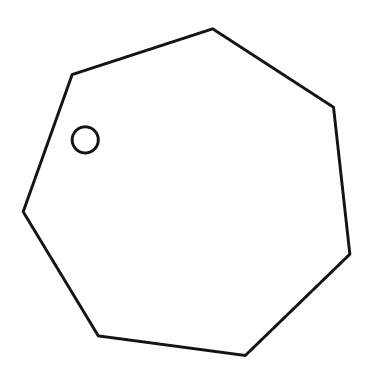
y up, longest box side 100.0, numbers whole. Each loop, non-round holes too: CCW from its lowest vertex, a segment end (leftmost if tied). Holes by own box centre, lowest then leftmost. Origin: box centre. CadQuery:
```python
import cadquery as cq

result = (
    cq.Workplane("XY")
    .moveTo(18.0, -50.0)
    .lineTo(50.0, -19.0)
    .lineTo(45.0, 26.0)
    .lineTo(8.0, 50.0)
    .lineTo(-35.0, 36.0)
    .lineTo(-50.0, -6.0)
    .lineTo(-27.0, -44.0)
    .close()
    .moveTo(-31.0, 16.0)
    .circle(4.0)
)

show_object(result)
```